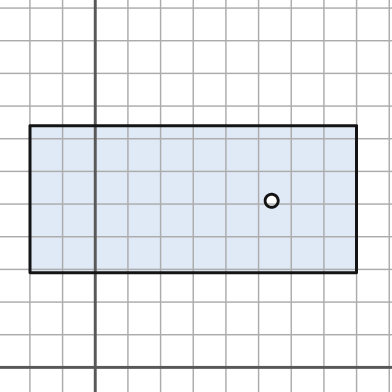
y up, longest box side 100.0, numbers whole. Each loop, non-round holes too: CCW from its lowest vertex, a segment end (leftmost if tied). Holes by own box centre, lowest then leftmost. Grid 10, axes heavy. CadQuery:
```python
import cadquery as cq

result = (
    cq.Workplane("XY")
    .moveTo(-20.0, 29.0)
    .lineTo(80.0, 29.0)
    .lineTo(80.0, 74.0)
    .lineTo(-20.0, 74.0)
    .close()
    .moveTo(54.0, 51.0)
    .circle(2.0)
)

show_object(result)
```